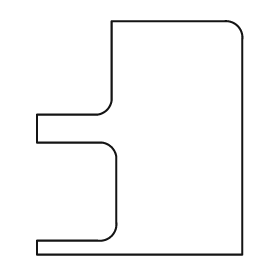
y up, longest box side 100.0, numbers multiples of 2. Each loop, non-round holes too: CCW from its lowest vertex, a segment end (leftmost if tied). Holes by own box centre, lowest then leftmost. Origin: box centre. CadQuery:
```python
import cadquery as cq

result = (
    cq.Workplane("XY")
    .moveTo(-44.0, -50.0)
    .lineTo(44.0, -50.0)
    .lineTo(44.0, 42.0)
    .threePointArc((42.0, 48.0), (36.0, 50.0))
    .lineTo(-12.0, 50.0)
    .lineTo(-12.0, 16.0)
    .threePointArc((-14.0, 12.0), (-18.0, 10.0))
    .lineTo(-44.0, 10.0)
    .lineTo(-44.0, -2.0)
    .lineTo(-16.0, -2.0)
    .threePointArc((-12.0, -4.0), (-10.0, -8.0))
    .lineTo(-10.0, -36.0)
    .threePointArc((-12.0, -42.0), (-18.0, -44.0))
    .lineTo(-44.0, -44.0)
    .close()
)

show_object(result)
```